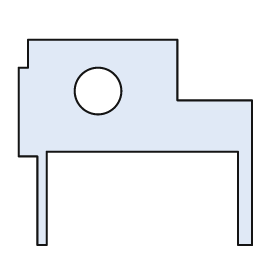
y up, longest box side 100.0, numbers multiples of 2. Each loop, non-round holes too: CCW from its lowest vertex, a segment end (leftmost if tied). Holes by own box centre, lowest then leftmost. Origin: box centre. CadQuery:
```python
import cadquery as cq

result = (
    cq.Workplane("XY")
    .moveTo(-42.0, -44.0)
    .lineTo(-38.0, -44.0)
    .lineTo(-38.0, -4.0)
    .lineTo(44.0, -4.0)
    .lineTo(44.0, -44.0)
    .lineTo(50.0, -44.0)
    .lineTo(50.0, 18.0)
    .lineTo(18.0, 18.0)
    .lineTo(18.0, 44.0)
    .lineTo(-46.0, 44.0)
    .lineTo(-46.0, 32.0)
    .lineTo(-50.0, 32.0)
    .lineTo(-50.0, -6.0)
    .lineTo(-42.0, -6.0)
    .close()
    .moveTo(-16.0, 22.0)
    .circle(10.0)
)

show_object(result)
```